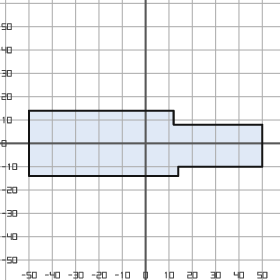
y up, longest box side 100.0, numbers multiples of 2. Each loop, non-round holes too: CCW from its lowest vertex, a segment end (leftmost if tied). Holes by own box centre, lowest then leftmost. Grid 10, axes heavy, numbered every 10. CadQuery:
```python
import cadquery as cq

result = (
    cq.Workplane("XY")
    .moveTo(-50.0, -14.0)
    .lineTo(14.0, -14.0)
    .lineTo(14.0, -10.0)
    .lineTo(50.0, -10.0)
    .lineTo(50.0, 8.0)
    .lineTo(12.0, 8.0)
    .lineTo(12.0, 14.0)
    .lineTo(-50.0, 14.0)
    .close()
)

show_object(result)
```